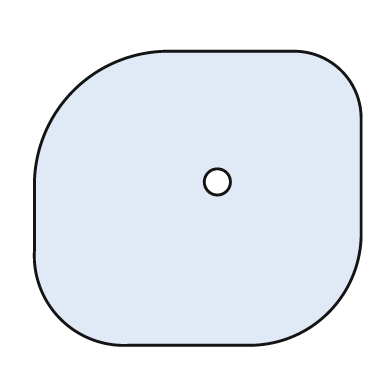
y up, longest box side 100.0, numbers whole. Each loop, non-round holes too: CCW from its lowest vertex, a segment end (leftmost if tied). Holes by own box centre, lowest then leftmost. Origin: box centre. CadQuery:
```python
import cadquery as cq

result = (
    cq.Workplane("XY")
    .moveTo(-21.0, -45.0)
    .lineTo(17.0, -45.0)
    .threePointArc((40.0, -35.0), (50.0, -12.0))
    .lineTo(50.0, 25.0)
    .threePointArc((44.0, 39.0), (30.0, 45.0))
    .lineTo(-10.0, 45.0)
    .threePointArc((-38.0, 33.0), (-50.0, 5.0))
    .lineTo(-50.0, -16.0)
    .threePointArc((-42.0, -37.0), (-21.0, -45.0))
    .close()
    .moveTo(6.0, 5.0)
    .circle(4.0)
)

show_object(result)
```